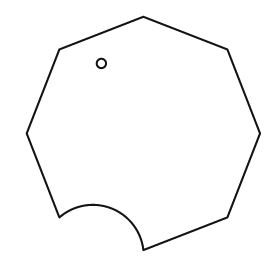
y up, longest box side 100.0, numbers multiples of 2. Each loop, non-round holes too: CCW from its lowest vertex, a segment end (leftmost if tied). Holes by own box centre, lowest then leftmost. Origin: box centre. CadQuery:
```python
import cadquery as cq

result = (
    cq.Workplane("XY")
    .moveTo(0.0, -50.0)
    .lineTo(36.0, -36.0)
    .lineTo(50.0, 0.0)
    .lineTo(36.0, 36.0)
    .lineTo(0.0, 50.0)
    .lineTo(-36.0, 36.0)
    .lineTo(-50.0, 0.0)
    .lineTo(-36.0, -36.0)
    .threePointArc((-14.0, -32.0), (0.0, -50.0))
    .close()
    .moveTo(-18.0, 30.0)
    .circle(2.0)
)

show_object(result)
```